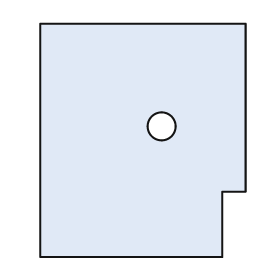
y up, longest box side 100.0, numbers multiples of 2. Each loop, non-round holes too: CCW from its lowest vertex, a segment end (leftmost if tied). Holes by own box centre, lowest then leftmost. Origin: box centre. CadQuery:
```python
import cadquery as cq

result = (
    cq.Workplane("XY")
    .moveTo(-44.0, -50.0)
    .lineTo(34.0, -50.0)
    .lineTo(34.0, -22.0)
    .lineTo(44.0, -22.0)
    .lineTo(44.0, 50.0)
    .lineTo(-44.0, 50.0)
    .close()
    .moveTo(8.0, 6.0)
    .circle(6.0)
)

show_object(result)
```